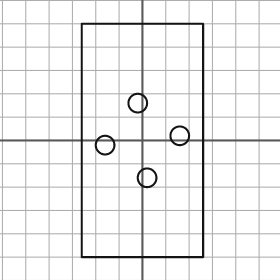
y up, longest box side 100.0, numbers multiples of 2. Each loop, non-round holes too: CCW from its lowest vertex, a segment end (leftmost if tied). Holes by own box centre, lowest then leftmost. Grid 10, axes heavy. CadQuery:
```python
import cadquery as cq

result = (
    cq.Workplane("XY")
    .moveTo(-26.0, -50.0)
    .lineTo(26.0, -50.0)
    .lineTo(26.0, 50.0)
    .lineTo(-26.0, 50.0)
    .close()
    .moveTo(2.0, -16.0)
    .circle(4.0)
    .moveTo(-16.0, -2.0)
    .circle(4.0)
    .moveTo(16.0, 2.0)
    .circle(4.0)
    .moveTo(-2.0, 16.0)
    .circle(4.0)
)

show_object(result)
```